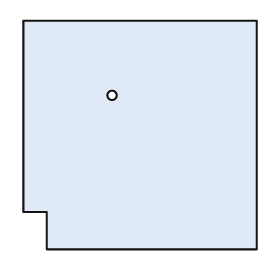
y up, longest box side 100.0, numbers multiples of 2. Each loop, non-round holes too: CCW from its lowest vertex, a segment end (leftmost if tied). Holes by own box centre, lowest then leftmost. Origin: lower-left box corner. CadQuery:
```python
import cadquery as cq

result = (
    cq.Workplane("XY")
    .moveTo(10.0, 0.0)
    .lineTo(100.0, 0.0)
    .lineTo(100.0, 98.0)
    .lineTo(0.0, 98.0)
    .lineTo(0.0, 16.0)
    .lineTo(10.0, 16.0)
    .close()
    .moveTo(38.0, 66.0)
    .circle(2.0)
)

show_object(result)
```